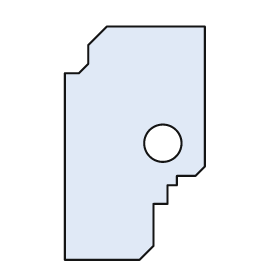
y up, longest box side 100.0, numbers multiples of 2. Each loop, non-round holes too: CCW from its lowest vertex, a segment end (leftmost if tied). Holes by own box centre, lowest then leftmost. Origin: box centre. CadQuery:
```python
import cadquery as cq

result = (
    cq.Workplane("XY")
    .moveTo(-30.0, -50.0)
    .lineTo(2.0, -50.0)
    .lineTo(8.0, -44.0)
    .lineTo(8.0, -26.0)
    .lineTo(14.0, -26.0)
    .lineTo(14.0, -18.0)
    .lineTo(18.0, -18.0)
    .lineTo(18.0, -14.0)
    .lineTo(26.0, -14.0)
    .lineTo(30.0, -10.0)
    .lineTo(30.0, 50.0)
    .lineTo(-12.0, 50.0)
    .lineTo(-20.0, 42.0)
    .lineTo(-20.0, 34.0)
    .lineTo(-24.0, 30.0)
    .lineTo(-30.0, 30.0)
    .close()
    .moveTo(12.0, 0.0)
    .circle(8.0)
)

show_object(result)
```